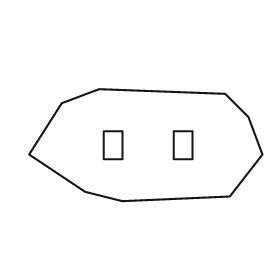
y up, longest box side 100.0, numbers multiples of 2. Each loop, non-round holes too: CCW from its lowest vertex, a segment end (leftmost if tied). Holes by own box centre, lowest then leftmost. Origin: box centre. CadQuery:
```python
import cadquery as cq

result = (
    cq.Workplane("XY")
    .moveTo(-10.0, -24.0)
    .lineTo(36.0, -22.0)
    .lineTo(50.0, -4.0)
    .lineTo(44.0, 12.0)
    .lineTo(34.0, 22.0)
    .lineTo(-20.0, 24.0)
    .lineTo(-36.0, 18.0)
    .lineTo(-50.0, -4.0)
    .lineTo(-26.0, -20.0)
    .close()
    .moveTo(-18.0, -6.0)
    .lineTo(-10.0, -6.0)
    .lineTo(-10.0, 6.0)
    .lineTo(-18.0, 6.0)
    .close()
    .moveTo(12.0, -6.0)
    .lineTo(20.0, -6.0)
    .lineTo(20.0, 6.0)
    .lineTo(12.0, 6.0)
    .close()
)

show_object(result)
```